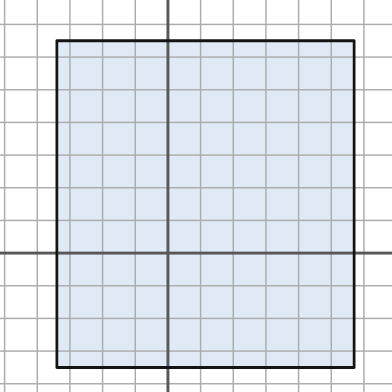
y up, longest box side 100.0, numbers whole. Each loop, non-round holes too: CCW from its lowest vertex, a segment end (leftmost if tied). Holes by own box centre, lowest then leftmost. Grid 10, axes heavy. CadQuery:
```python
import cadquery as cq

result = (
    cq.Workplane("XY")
    .moveTo(-34.0, -35.0)
    .lineTo(57.0, -35.0)
    .lineTo(57.0, 65.0)
    .lineTo(-34.0, 65.0)
    .close()
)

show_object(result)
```